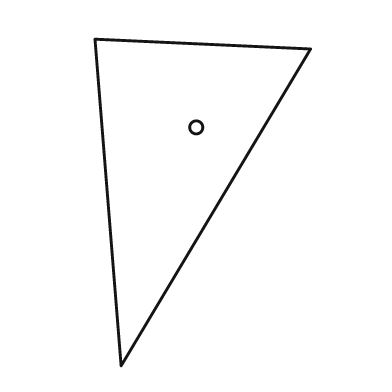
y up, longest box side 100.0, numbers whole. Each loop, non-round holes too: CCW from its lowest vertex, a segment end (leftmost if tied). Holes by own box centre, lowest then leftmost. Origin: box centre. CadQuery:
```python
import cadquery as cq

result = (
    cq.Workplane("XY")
    .moveTo(-25.0, -50.0)
    .lineTo(33.0, 47.0)
    .lineTo(-33.0, 50.0)
    .close()
    .moveTo(-2.0, 23.0)
    .circle(2.0)
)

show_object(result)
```